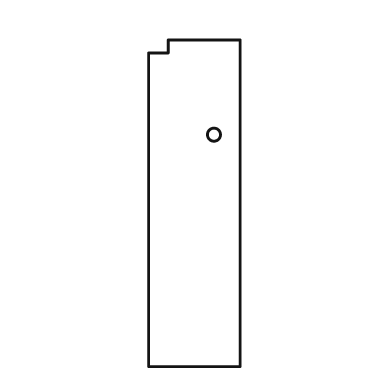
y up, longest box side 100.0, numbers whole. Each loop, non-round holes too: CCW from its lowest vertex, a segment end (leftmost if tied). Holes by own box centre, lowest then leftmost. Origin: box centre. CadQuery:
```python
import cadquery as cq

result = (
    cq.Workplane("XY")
    .moveTo(-14.0, -50.0)
    .lineTo(14.0, -50.0)
    .lineTo(14.0, 50.0)
    .lineTo(-8.0, 50.0)
    .lineTo(-8.0, 46.0)
    .lineTo(-14.0, 46.0)
    .close()
    .moveTo(6.0, 21.0)
    .circle(2.0)
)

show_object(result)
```